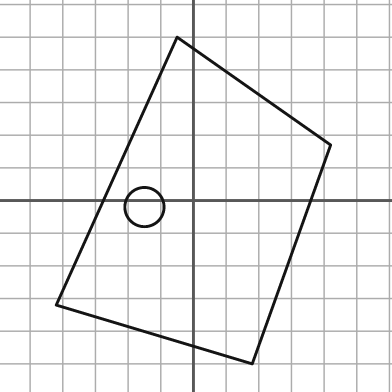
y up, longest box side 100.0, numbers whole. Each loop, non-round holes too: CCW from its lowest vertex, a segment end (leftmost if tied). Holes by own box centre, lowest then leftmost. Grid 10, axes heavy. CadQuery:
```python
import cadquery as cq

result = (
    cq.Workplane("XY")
    .moveTo(18.0, -50.0)
    .lineTo(42.0, 17.0)
    .lineTo(-5.0, 50.0)
    .lineTo(-42.0, -32.0)
    .close()
    .moveTo(-15.0, -2.0)
    .circle(6.0)
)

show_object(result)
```